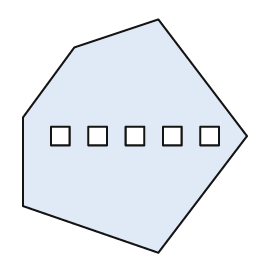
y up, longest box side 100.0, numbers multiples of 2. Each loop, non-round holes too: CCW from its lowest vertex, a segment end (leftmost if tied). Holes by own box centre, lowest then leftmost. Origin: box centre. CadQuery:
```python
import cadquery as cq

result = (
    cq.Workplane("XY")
    .moveTo(10.0, -50.0)
    .lineTo(48.0, 0.0)
    .lineTo(10.0, 50.0)
    .lineTo(-26.0, 38.0)
    .lineTo(-48.0, 8.0)
    .lineTo(-48.0, -30.0)
    .close()
    .moveTo(-36.0, -4.0)
    .lineTo(-28.0, -4.0)
    .lineTo(-28.0, 4.0)
    .lineTo(-36.0, 4.0)
    .close()
    .moveTo(-20.0, -4.0)
    .lineTo(-12.0, -4.0)
    .lineTo(-12.0, 4.0)
    .lineTo(-20.0, 4.0)
    .close()
    .moveTo(-4.0, -4.0)
    .lineTo(4.0, -4.0)
    .lineTo(4.0, 4.0)
    .lineTo(-4.0, 4.0)
    .close()
    .moveTo(12.0, -4.0)
    .lineTo(20.0, -4.0)
    .lineTo(20.0, 4.0)
    .lineTo(12.0, 4.0)
    .close()
    .moveTo(28.0, -4.0)
    .lineTo(36.0, -4.0)
    .lineTo(36.0, 4.0)
    .lineTo(28.0, 4.0)
    .close()
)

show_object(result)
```